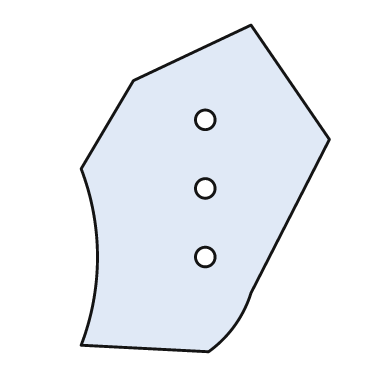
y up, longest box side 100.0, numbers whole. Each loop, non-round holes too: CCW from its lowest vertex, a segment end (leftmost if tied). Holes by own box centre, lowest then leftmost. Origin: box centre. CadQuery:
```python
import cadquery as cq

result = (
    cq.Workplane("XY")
    .moveTo(1.0, -50.0)
    .threePointArc((9.0, -42.0), (14.0, -32.0))
    .lineTo(38.0, 15.0)
    .lineTo(14.0, 50.0)
    .lineTo(-22.0, 33.0)
    .lineTo(-38.0, 6.0)
    .threePointArc((-33.0, -21.0), (-38.0, -48.0))
    .close()
    .moveTo(0.0, -21.0)
    .circle(3.0)
    .moveTo(0.0, 0.0)
    .circle(3.0)
    .moveTo(0.0, 21.0)
    .circle(3.0)
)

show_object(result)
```